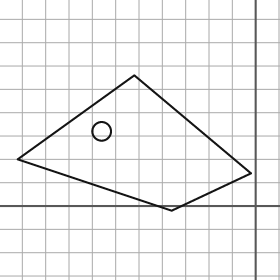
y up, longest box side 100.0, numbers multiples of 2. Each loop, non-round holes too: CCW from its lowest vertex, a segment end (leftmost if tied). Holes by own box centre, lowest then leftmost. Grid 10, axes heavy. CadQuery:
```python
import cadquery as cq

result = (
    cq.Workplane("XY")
    .moveTo(-36.0, -2.0)
    .lineTo(-2.0, 14.0)
    .lineTo(-52.0, 56.0)
    .lineTo(-102.0, 20.0)
    .close()
    .moveTo(-66.0, 32.0)
    .circle(4.0)
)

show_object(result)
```